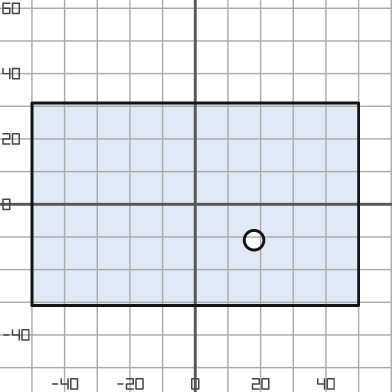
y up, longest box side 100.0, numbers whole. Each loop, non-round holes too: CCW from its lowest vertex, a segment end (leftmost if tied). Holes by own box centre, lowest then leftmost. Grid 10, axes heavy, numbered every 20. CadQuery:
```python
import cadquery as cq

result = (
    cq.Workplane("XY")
    .moveTo(-50.0, -31.0)
    .lineTo(50.0, -31.0)
    .lineTo(50.0, 31.0)
    .lineTo(-50.0, 31.0)
    .close()
    .moveTo(18.0, -11.0)
    .circle(3.0)
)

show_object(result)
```